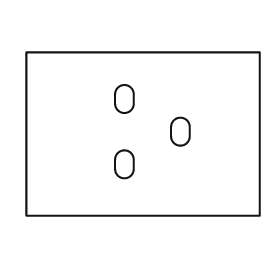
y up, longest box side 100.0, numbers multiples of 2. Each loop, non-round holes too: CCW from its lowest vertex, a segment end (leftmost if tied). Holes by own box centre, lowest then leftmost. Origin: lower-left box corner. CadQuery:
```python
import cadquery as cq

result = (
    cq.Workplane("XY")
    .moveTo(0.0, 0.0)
    .lineTo(100.0, 0.0)
    .lineTo(100.0, 70.0)
    .lineTo(0.0, 70.0)
    .close()
    .moveTo(38.0, 20.0)
    .threePointArc((42.0, 16.0), (46.0, 20.0))
    .lineTo(46.0, 24.0)
    .threePointArc((42.0, 28.0), (38.0, 24.0))
    .close()
    .moveTo(62.0, 34.0)
    .threePointArc((66.0, 30.0), (70.0, 34.0))
    .lineTo(70.0, 38.0)
    .threePointArc((66.0, 42.0), (62.0, 38.0))
    .close()
    .moveTo(38.0, 48.0)
    .threePointArc((42.0, 44.0), (46.0, 48.0))
    .lineTo(46.0, 52.0)
    .threePointArc((42.0, 56.0), (38.0, 52.0))
    .close()
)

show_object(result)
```